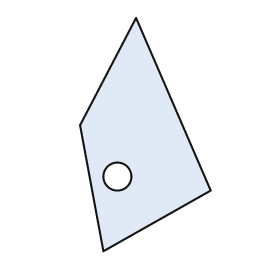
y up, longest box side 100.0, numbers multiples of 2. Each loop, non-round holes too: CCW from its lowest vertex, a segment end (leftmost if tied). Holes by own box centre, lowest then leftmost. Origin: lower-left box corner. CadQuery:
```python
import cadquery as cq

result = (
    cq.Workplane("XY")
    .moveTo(10.0, 0.0)
    .lineTo(56.0, 26.0)
    .lineTo(24.0, 100.0)
    .lineTo(0.0, 54.0)
    .close()
    .moveTo(16.0, 32.0)
    .circle(6.0)
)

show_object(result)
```